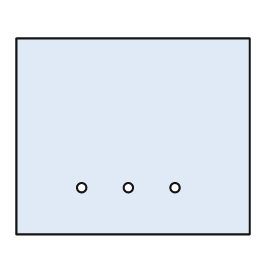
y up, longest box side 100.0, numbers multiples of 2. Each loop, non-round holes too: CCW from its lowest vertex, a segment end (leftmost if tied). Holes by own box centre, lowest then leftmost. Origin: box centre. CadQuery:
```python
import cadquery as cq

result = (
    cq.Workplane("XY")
    .moveTo(-50.0, -42.0)
    .lineTo(50.0, -42.0)
    .lineTo(50.0, 42.0)
    .lineTo(-50.0, 42.0)
    .close()
    .moveTo(-22.0, -22.0)
    .circle(2.0)
    .moveTo(-2.0, -22.0)
    .circle(2.0)
    .moveTo(18.0, -22.0)
    .circle(2.0)
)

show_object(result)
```